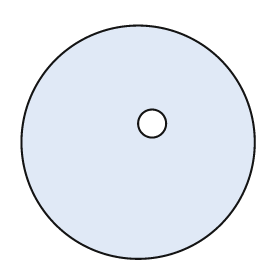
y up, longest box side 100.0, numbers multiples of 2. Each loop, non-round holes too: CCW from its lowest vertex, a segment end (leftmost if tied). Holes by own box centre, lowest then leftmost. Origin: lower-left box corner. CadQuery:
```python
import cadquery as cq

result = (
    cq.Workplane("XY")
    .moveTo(50.0, 50.0)
    .circle(50.0)
    .moveTo(56.0, 58.0)
    .circle(6.0)
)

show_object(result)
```